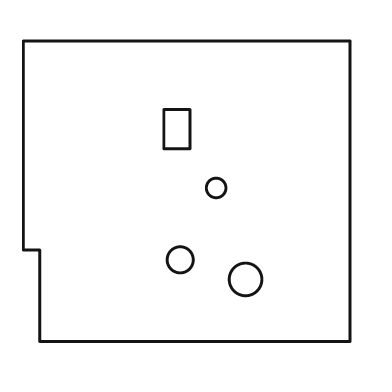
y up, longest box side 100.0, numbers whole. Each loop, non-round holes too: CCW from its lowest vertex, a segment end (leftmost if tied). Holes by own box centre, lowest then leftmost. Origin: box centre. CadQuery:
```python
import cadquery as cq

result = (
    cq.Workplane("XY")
    .moveTo(-45.0, -46.0)
    .lineTo(50.0, -46.0)
    .lineTo(50.0, 46.0)
    .lineTo(-50.0, 46.0)
    .lineTo(-50.0, -18.0)
    .lineTo(-45.0, -18.0)
    .close()
    .moveTo(18.0, -27.0)
    .circle(5.0)
    .moveTo(-2.0, -21.0)
    .circle(4.0)
    .moveTo(9.0, 1.0)
    .circle(3.0)
    .moveTo(-7.0, 13.0)
    .lineTo(1.0, 13.0)
    .lineTo(1.0, 25.0)
    .lineTo(-7.0, 25.0)
    .close()
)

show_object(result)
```